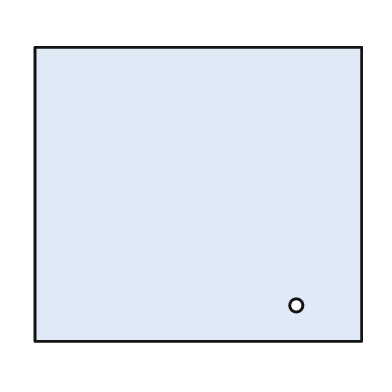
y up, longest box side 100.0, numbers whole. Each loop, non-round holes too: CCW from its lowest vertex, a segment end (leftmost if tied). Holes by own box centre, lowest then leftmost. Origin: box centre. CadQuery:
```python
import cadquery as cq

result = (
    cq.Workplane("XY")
    .moveTo(-50.0, -45.0)
    .lineTo(50.0, -45.0)
    .lineTo(50.0, 45.0)
    .lineTo(-50.0, 45.0)
    .close()
    .moveTo(30.0, -34.0)
    .circle(2.0)
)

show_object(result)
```